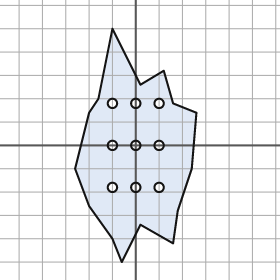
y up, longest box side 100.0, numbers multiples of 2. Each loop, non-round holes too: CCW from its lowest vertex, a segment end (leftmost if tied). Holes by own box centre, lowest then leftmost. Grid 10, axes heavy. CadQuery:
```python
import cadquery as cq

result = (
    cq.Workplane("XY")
    .moveTo(-6.0, -50.0)
    .lineTo(2.0, -34.0)
    .lineTo(16.0, -42.0)
    .lineTo(18.0, -28.0)
    .lineTo(24.0, -10.0)
    .lineTo(26.0, 14.0)
    .lineTo(16.0, 18.0)
    .lineTo(12.0, 32.0)
    .lineTo(2.0, 26.0)
    .lineTo(-10.0, 50.0)
    .lineTo(-16.0, 20.0)
    .lineTo(-20.0, 14.0)
    .lineTo(-26.0, -10.0)
    .lineTo(-20.0, -26.0)
    .lineTo(-10.0, -40.0)
    .close()
    .moveTo(-10.0, -18.0)
    .circle(2.0)
    .moveTo(0.0, -18.0)
    .circle(2.0)
    .moveTo(10.0, -18.0)
    .circle(2.0)
    .moveTo(-10.0, 0.0)
    .circle(2.0)
    .moveTo(0.0, 0.0)
    .circle(2.0)
    .moveTo(10.0, 0.0)
    .circle(2.0)
    .moveTo(-10.0, 18.0)
    .circle(2.0)
    .moveTo(0.0, 18.0)
    .circle(2.0)
    .moveTo(10.0, 18.0)
    .circle(2.0)
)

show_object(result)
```